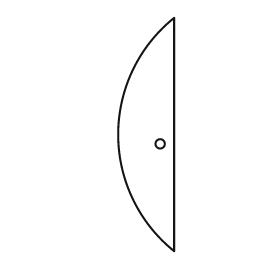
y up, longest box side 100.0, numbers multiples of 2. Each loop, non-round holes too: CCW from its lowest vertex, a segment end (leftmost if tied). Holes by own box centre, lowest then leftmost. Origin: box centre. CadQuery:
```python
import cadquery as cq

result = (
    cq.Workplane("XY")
    .moveTo(12.0, -50.0)
    .lineTo(12.0, 50.0)
    .threePointArc((-12.0, 0.0), (12.0, -50.0))
    .close()
    .moveTo(6.0, -4.0)
    .circle(2.0)
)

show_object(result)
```